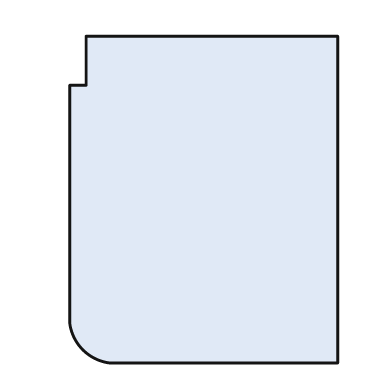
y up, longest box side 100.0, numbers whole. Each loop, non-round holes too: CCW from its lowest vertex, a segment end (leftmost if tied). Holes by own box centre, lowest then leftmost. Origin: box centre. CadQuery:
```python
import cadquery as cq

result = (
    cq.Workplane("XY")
    .moveTo(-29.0, -50.0)
    .lineTo(41.0, -50.0)
    .lineTo(41.0, 50.0)
    .lineTo(-36.0, 50.0)
    .lineTo(-36.0, 35.0)
    .lineTo(-41.0, 35.0)
    .lineTo(-41.0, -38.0)
    .threePointArc((-37.0, -46.0), (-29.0, -50.0))
    .close()
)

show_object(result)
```